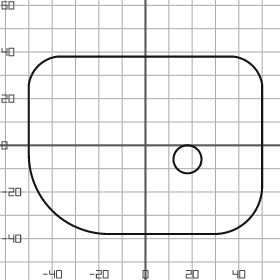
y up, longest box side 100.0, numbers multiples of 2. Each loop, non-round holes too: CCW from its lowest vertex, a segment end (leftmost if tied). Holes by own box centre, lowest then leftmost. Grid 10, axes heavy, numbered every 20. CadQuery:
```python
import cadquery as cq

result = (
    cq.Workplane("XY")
    .moveTo(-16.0, -38.0)
    .lineTo(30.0, -38.0)
    .threePointArc((44.0, -32.0), (50.0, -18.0))
    .lineTo(50.0, 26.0)
    .threePointArc((46.0, 34.0), (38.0, 38.0))
    .lineTo(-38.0, 38.0)
    .threePointArc((-46.0, 34.0), (-50.0, 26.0))
    .lineTo(-50.0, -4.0)
    .threePointArc((-40.0, -28.0), (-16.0, -38.0))
    .close()
    .moveTo(18.0, -6.0)
    .circle(6.0)
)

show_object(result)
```